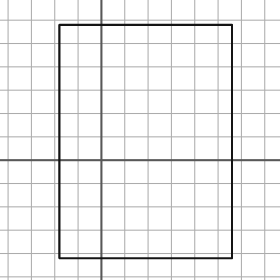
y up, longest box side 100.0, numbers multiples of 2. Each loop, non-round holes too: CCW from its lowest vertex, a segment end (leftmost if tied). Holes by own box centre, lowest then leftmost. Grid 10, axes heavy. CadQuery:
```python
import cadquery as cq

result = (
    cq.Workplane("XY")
    .moveTo(-18.0, -42.0)
    .lineTo(56.0, -42.0)
    .lineTo(56.0, 58.0)
    .lineTo(-18.0, 58.0)
    .close()
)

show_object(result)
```